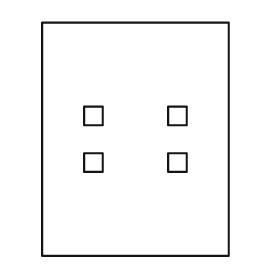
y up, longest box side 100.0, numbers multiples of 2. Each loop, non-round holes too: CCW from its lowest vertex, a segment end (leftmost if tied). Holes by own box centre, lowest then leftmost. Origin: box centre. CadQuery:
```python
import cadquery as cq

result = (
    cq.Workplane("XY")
    .moveTo(-40.0, -50.0)
    .lineTo(40.0, -50.0)
    .lineTo(40.0, 50.0)
    .lineTo(-40.0, 50.0)
    .close()
    .moveTo(-22.0, -14.0)
    .lineTo(-14.0, -14.0)
    .lineTo(-14.0, -6.0)
    .lineTo(-22.0, -6.0)
    .close()
    .moveTo(14.0, -14.0)
    .lineTo(22.0, -14.0)
    .lineTo(22.0, -6.0)
    .lineTo(14.0, -6.0)
    .close()
    .moveTo(-22.0, 6.0)
    .lineTo(-14.0, 6.0)
    .lineTo(-14.0, 14.0)
    .lineTo(-22.0, 14.0)
    .close()
    .moveTo(14.0, 6.0)
    .lineTo(22.0, 6.0)
    .lineTo(22.0, 14.0)
    .lineTo(14.0, 14.0)
    .close()
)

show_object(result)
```